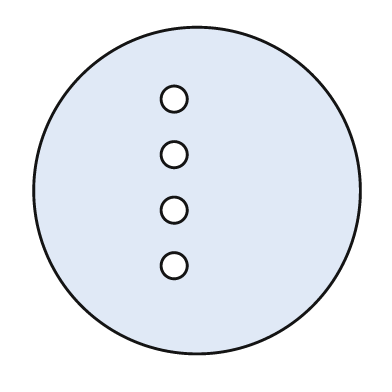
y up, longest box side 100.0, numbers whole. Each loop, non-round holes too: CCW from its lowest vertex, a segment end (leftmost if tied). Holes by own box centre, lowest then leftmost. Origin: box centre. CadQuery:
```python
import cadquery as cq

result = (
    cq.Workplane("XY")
    .moveTo(0.0, 0.0)
    .circle(50.0)
    .moveTo(-7.0, -23.0)
    .circle(4.0)
    .moveTo(-7.0, -6.0)
    .circle(4.0)
    .moveTo(-7.0, 11.0)
    .circle(4.0)
    .moveTo(-7.0, 28.0)
    .circle(4.0)
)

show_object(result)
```